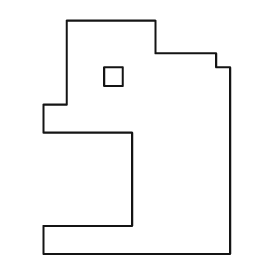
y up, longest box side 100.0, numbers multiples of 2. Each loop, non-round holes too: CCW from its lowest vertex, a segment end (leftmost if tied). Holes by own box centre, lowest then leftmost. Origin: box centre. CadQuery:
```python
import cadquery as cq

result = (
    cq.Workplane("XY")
    .moveTo(-40.0, -50.0)
    .lineTo(40.0, -50.0)
    .lineTo(40.0, 30.0)
    .lineTo(34.0, 30.0)
    .lineTo(34.0, 36.0)
    .lineTo(8.0, 36.0)
    .lineTo(8.0, 50.0)
    .lineTo(-30.0, 50.0)
    .lineTo(-30.0, 14.0)
    .lineTo(-40.0, 14.0)
    .lineTo(-40.0, 2.0)
    .lineTo(-2.0, 2.0)
    .lineTo(-2.0, -38.0)
    .lineTo(-40.0, -38.0)
    .close()
    .moveTo(-14.0, 22.0)
    .lineTo(-6.0, 22.0)
    .lineTo(-6.0, 30.0)
    .lineTo(-14.0, 30.0)
    .close()
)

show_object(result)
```